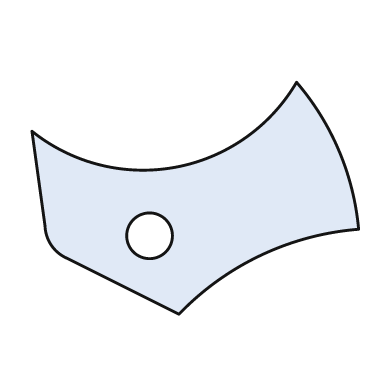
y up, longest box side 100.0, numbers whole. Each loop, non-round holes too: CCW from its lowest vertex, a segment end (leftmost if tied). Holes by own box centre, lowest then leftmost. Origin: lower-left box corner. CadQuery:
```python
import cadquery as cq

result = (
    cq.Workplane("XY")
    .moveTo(45.0, 0.0)
    .threePointArc((70.0, 18.0), (100.0, 26.0))
    .threePointArc((94.0, 50.0), (81.0, 71.0))
    .threePointArc((44.0, 45.0), (0.0, 56.0))
    .lineTo(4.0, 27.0)
    .threePointArc((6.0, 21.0), (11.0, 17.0))
    .close()
    .moveTo(36.0, 24.0)
    .circle(7.0)
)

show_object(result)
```